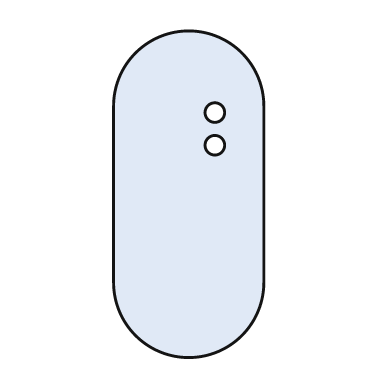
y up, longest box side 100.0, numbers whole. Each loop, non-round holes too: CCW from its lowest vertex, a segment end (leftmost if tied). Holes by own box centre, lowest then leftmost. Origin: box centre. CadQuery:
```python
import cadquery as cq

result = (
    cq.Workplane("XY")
    .moveTo(-23.0, -27.0)
    .threePointArc((0.0, -50.0), (23.0, -27.0))
    .lineTo(23.0, 27.0)
    .threePointArc((0.0, 50.0), (-23.0, 27.0))
    .close()
    .moveTo(8.0, 15.0)
    .circle(3.0)
    .moveTo(8.0, 25.0)
    .circle(3.0)
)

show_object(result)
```